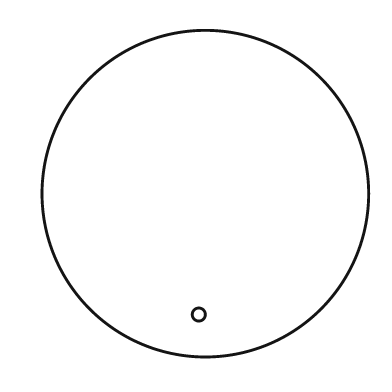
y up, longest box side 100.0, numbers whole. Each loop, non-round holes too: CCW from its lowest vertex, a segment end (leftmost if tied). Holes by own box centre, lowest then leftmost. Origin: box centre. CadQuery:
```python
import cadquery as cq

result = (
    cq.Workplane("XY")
    .moveTo(0.0, 0.0)
    .circle(50.0)
    .moveTo(-2.0, -37.0)
    .circle(2.0)
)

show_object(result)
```